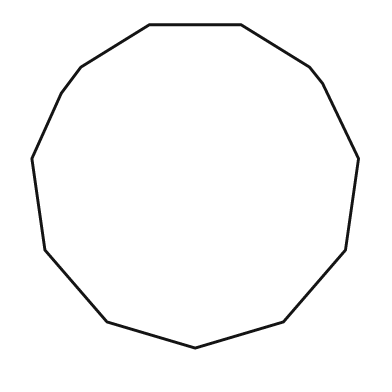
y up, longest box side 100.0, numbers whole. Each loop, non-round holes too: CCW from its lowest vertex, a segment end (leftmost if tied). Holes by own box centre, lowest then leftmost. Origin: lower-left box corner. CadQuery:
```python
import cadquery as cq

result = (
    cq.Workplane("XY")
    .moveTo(50.0, 0.0)
    .lineTo(77.0, 8.0)
    .lineTo(96.0, 30.0)
    .lineTo(100.0, 58.0)
    .lineTo(89.0, 81.0)
    .lineTo(85.0, 86.0)
    .lineTo(64.0, 99.0)
    .lineTo(36.0, 99.0)
    .lineTo(15.0, 86.0)
    .lineTo(9.0, 78.0)
    .lineTo(0.0, 58.0)
    .lineTo(4.0, 30.0)
    .lineTo(23.0, 8.0)
    .close()
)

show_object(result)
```